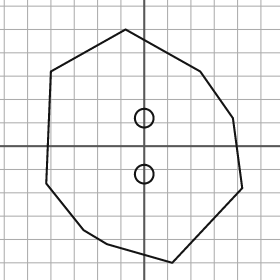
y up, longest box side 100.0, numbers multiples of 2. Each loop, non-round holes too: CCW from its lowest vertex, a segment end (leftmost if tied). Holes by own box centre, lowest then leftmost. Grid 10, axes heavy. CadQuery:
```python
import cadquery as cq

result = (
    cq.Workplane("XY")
    .moveTo(12.0, -50.0)
    .lineTo(42.0, -18.0)
    .lineTo(38.0, 12.0)
    .lineTo(24.0, 32.0)
    .lineTo(-8.0, 50.0)
    .lineTo(-40.0, 32.0)
    .lineTo(-42.0, -16.0)
    .lineTo(-26.0, -36.0)
    .lineTo(-16.0, -42.0)
    .close()
    .moveTo(0.0, -12.0)
    .circle(4.0)
    .moveTo(0.0, 12.0)
    .circle(4.0)
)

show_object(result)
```